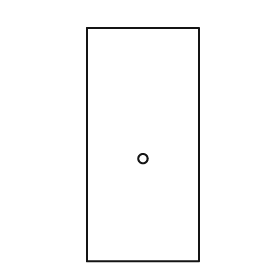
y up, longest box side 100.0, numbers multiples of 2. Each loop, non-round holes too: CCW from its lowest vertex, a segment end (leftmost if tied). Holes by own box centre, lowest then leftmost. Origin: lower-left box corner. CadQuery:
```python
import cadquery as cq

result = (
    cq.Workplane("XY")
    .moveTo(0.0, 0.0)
    .lineTo(48.0, 0.0)
    .lineTo(48.0, 100.0)
    .lineTo(0.0, 100.0)
    .close()
    .moveTo(24.0, 44.0)
    .circle(2.0)
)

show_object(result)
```